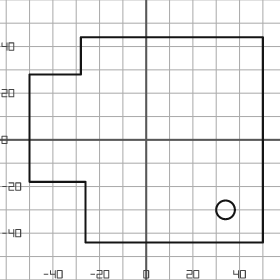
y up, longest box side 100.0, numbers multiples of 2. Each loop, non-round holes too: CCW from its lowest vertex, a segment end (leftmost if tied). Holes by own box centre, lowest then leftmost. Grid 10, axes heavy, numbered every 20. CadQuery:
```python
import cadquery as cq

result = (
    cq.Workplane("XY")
    .moveTo(-26.0, -44.0)
    .lineTo(50.0, -44.0)
    .lineTo(50.0, 44.0)
    .lineTo(-28.0, 44.0)
    .lineTo(-28.0, 28.0)
    .lineTo(-50.0, 28.0)
    .lineTo(-50.0, -18.0)
    .lineTo(-26.0, -18.0)
    .close()
    .moveTo(34.0, -30.0)
    .circle(4.0)
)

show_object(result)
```